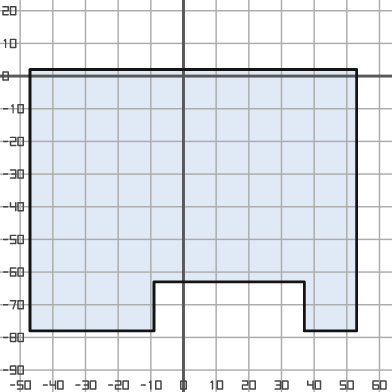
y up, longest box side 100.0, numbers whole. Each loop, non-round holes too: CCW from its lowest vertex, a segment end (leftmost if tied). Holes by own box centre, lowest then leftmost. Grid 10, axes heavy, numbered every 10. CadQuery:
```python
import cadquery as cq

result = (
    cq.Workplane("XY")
    .moveTo(-47.0, -78.0)
    .lineTo(-9.0, -78.0)
    .lineTo(-9.0, -63.0)
    .lineTo(37.0, -63.0)
    .lineTo(37.0, -78.0)
    .lineTo(53.0, -78.0)
    .lineTo(53.0, 2.0)
    .lineTo(-47.0, 2.0)
    .close()
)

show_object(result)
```